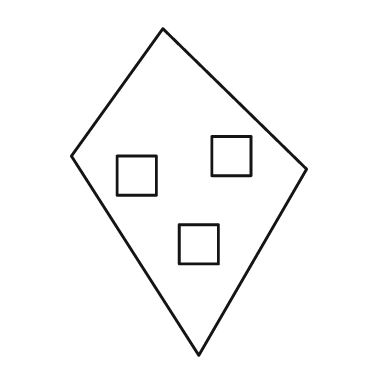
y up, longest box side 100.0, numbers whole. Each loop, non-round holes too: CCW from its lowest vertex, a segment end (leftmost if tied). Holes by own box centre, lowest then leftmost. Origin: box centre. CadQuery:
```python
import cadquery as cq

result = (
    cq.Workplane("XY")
    .moveTo(3.0, -50.0)
    .lineTo(36.0, 7.0)
    .lineTo(-8.0, 50.0)
    .lineTo(-36.0, 11.0)
    .close()
    .moveTo(-3.0, -22.0)
    .lineTo(9.0, -22.0)
    .lineTo(9.0, -10.0)
    .lineTo(-3.0, -10.0)
    .close()
    .moveTo(-22.0, -1.0)
    .lineTo(-10.0, -1.0)
    .lineTo(-10.0, 11.0)
    .lineTo(-22.0, 11.0)
    .close()
    .moveTo(7.0, 5.0)
    .lineTo(19.0, 5.0)
    .lineTo(19.0, 17.0)
    .lineTo(7.0, 17.0)
    .close()
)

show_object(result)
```